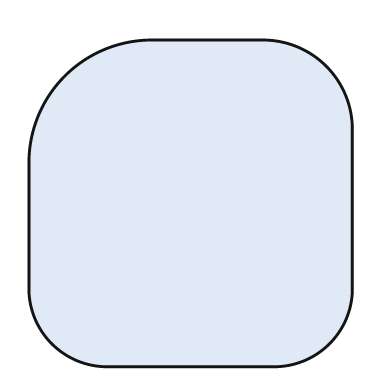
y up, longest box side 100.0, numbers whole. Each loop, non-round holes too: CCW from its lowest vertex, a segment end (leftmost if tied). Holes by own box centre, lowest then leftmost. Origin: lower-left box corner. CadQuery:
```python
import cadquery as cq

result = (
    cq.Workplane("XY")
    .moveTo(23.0, 0.0)
    .lineTo(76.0, 0.0)
    .threePointArc((92.0, 7.0), (99.0, 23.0))
    .lineTo(99.0, 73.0)
    .threePointArc((91.0, 92.0), (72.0, 100.0))
    .lineTo(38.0, 100.0)
    .threePointArc((11.0, 89.0), (0.0, 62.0))
    .lineTo(0.0, 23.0)
    .threePointArc((7.0, 7.0), (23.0, 0.0))
    .close()
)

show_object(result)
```